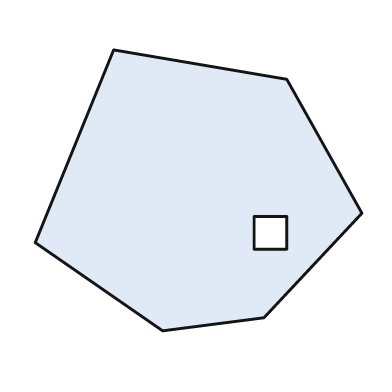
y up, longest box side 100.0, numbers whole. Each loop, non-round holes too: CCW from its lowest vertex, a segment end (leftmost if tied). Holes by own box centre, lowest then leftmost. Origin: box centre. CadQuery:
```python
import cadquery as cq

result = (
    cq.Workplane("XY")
    .moveTo(-11.0, -43.0)
    .lineTo(20.0, -39.0)
    .lineTo(50.0, -7.0)
    .lineTo(27.0, 34.0)
    .lineTo(-26.0, 43.0)
    .lineTo(-50.0, -16.0)
    .close()
    .moveTo(17.0, -18.0)
    .lineTo(27.0, -18.0)
    .lineTo(27.0, -8.0)
    .lineTo(17.0, -8.0)
    .close()
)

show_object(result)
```